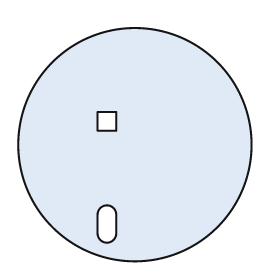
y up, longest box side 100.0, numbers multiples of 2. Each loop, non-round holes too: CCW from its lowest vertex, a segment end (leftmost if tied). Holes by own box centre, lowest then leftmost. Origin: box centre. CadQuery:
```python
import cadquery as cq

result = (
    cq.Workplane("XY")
    .moveTo(0.0, 0.0)
    .circle(50.0)
    .moveTo(-16.0, -38.0)
    .threePointArc((-12.0, -42.0), (-8.0, -38.0))
    .lineTo(-8.0, -30.0)
    .threePointArc((-12.0, -26.0), (-16.0, -30.0))
    .close()
    .moveTo(-16.0, 6.0)
    .lineTo(-8.0, 6.0)
    .lineTo(-8.0, 14.0)
    .lineTo(-16.0, 14.0)
    .close()
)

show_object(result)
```